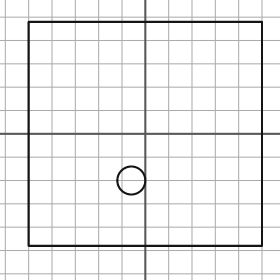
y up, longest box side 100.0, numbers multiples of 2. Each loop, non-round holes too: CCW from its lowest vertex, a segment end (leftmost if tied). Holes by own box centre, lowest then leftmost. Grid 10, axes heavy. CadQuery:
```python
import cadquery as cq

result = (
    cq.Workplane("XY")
    .moveTo(-50.0, -48.0)
    .lineTo(50.0, -48.0)
    .lineTo(50.0, 48.0)
    .lineTo(-50.0, 48.0)
    .close()
    .moveTo(-6.0, -20.0)
    .circle(6.0)
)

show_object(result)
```